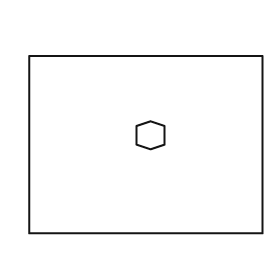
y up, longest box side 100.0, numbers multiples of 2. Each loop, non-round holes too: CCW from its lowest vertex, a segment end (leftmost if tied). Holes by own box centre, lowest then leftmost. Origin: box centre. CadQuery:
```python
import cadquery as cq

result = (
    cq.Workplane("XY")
    .moveTo(-50.0, -38.0)
    .lineTo(50.0, -38.0)
    .lineTo(50.0, 38.0)
    .lineTo(-50.0, 38.0)
    .close()
    .moveTo(2.0, -2.0)
    .lineTo(8.0, 0.0)
    .lineTo(8.0, 8.0)
    .lineTo(2.0, 10.0)
    .lineTo(-4.0, 8.0)
    .lineTo(-4.0, 0.0)
    .close()
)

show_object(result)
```